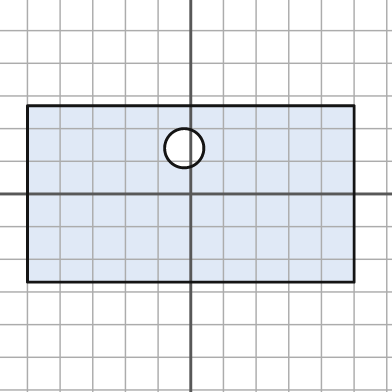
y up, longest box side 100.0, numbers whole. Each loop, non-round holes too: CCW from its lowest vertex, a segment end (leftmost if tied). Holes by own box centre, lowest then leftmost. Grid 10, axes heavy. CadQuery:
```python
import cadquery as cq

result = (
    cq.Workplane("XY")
    .moveTo(-50.0, -27.0)
    .lineTo(50.0, -27.0)
    .lineTo(50.0, 27.0)
    .lineTo(-50.0, 27.0)
    .close()
    .moveTo(-2.0, 14.0)
    .circle(6.0)
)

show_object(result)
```